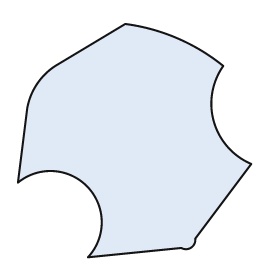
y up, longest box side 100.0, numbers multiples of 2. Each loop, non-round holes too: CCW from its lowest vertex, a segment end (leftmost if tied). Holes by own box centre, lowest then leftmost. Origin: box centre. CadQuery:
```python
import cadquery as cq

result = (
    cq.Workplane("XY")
    .moveTo(-20.0, -50.0)
    .lineTo(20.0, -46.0)
    .threePointArc((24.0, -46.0), (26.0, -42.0))
    .lineTo(50.0, -10.0)
    .threePointArc((34.0, 8.0), (38.0, 32.0))
    .threePointArc((18.0, 44.0), (-4.0, 50.0))
    .lineTo(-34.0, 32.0)
    .threePointArc((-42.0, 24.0), (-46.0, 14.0))
    .lineTo(-50.0, -18.0)
    .threePointArc((-20.0, -20.0), (-20.0, -50.0))
    .close()
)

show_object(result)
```